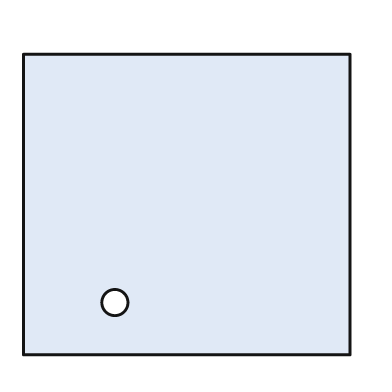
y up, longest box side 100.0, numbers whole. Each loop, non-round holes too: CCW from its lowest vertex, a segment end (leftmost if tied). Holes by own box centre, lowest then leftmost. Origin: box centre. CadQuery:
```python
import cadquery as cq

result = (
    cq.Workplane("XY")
    .moveTo(-50.0, -46.0)
    .lineTo(50.0, -46.0)
    .lineTo(50.0, 46.0)
    .lineTo(-50.0, 46.0)
    .close()
    .moveTo(-22.0, -30.0)
    .circle(4.0)
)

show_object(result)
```